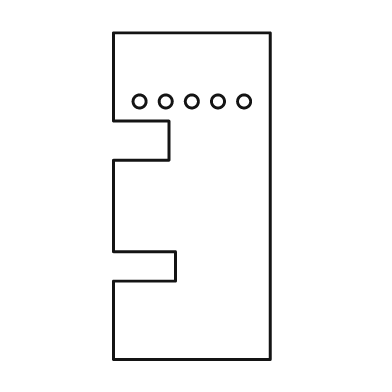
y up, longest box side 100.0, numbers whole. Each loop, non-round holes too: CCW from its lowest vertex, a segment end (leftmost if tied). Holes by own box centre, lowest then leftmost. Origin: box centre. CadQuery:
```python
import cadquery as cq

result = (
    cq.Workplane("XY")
    .moveTo(-24.0, -50.0)
    .lineTo(24.0, -50.0)
    .lineTo(24.0, 50.0)
    .lineTo(-24.0, 50.0)
    .lineTo(-24.0, 23.0)
    .lineTo(-7.0, 23.0)
    .lineTo(-7.0, 11.0)
    .lineTo(-24.0, 11.0)
    .lineTo(-24.0, -17.0)
    .lineTo(-5.0, -17.0)
    .lineTo(-5.0, -26.0)
    .lineTo(-24.0, -26.0)
    .close()
    .moveTo(-16.0, 29.0)
    .circle(2.0)
    .moveTo(-8.0, 29.0)
    .circle(2.0)
    .moveTo(0.0, 29.0)
    .circle(2.0)
    .moveTo(8.0, 29.0)
    .circle(2.0)
    .moveTo(16.0, 29.0)
    .circle(2.0)
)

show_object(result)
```